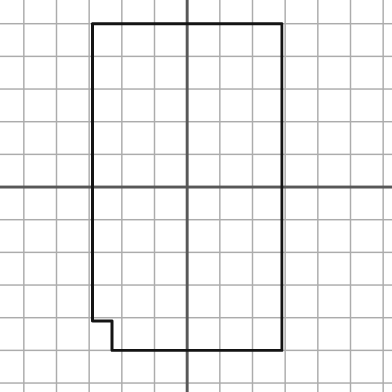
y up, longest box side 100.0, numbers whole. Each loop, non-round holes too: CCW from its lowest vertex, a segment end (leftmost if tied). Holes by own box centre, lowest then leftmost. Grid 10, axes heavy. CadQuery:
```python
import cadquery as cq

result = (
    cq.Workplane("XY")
    .moveTo(-23.0, -50.0)
    .lineTo(29.0, -50.0)
    .lineTo(29.0, 50.0)
    .lineTo(-29.0, 50.0)
    .lineTo(-29.0, -41.0)
    .lineTo(-23.0, -41.0)
    .close()
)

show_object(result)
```